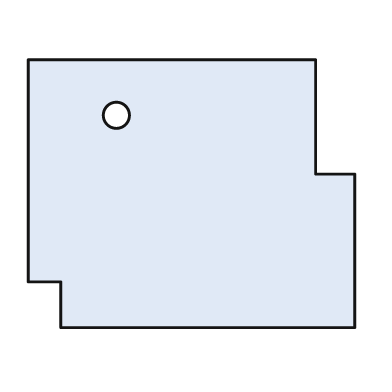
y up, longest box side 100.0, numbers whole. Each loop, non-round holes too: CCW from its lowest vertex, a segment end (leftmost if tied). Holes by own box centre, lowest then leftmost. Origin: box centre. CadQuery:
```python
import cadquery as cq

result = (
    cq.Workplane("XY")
    .moveTo(-40.0, -41.0)
    .lineTo(50.0, -41.0)
    .lineTo(50.0, 6.0)
    .lineTo(38.0, 6.0)
    .lineTo(38.0, 41.0)
    .lineTo(-50.0, 41.0)
    .lineTo(-50.0, -27.0)
    .lineTo(-40.0, -27.0)
    .close()
    .moveTo(-23.0, 24.0)
    .circle(4.0)
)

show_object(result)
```